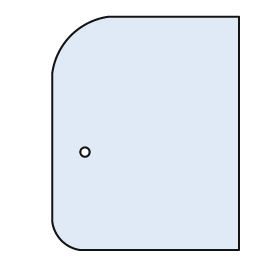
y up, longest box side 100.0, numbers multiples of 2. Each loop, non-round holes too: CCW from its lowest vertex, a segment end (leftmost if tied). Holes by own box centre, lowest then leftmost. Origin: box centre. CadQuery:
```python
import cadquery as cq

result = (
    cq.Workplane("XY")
    .moveTo(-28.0, -50.0)
    .lineTo(40.0, -50.0)
    .lineTo(40.0, 50.0)
    .lineTo(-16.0, 50.0)
    .threePointArc((-32.0, 42.0), (-40.0, 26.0))
    .lineTo(-40.0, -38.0)
    .threePointArc((-36.0, -46.0), (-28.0, -50.0))
    .close()
    .moveTo(-26.0, -8.0)
    .circle(2.0)
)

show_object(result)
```